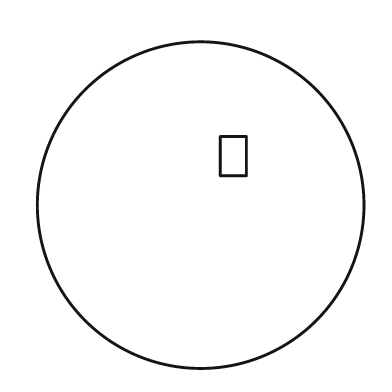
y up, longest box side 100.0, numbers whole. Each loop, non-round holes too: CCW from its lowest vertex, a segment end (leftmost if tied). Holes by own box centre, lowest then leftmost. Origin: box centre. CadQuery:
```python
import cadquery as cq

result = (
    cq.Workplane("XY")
    .moveTo(0.0, 0.0)
    .circle(50.0)
    .moveTo(6.0, 9.0)
    .lineTo(14.0, 9.0)
    .lineTo(14.0, 21.0)
    .lineTo(6.0, 21.0)
    .close()
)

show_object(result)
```